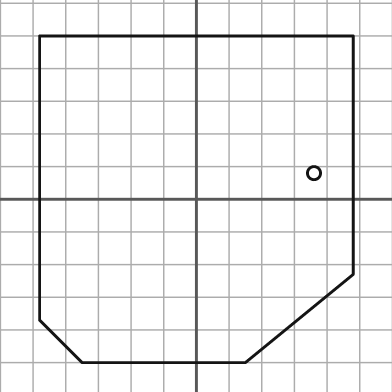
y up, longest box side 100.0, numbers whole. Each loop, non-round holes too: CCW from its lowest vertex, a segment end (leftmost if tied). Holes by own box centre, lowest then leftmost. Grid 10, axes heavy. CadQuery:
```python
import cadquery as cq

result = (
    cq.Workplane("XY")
    .moveTo(-35.0, -50.0)
    .lineTo(15.0, -50.0)
    .lineTo(48.0, -23.0)
    .lineTo(48.0, 50.0)
    .lineTo(-48.0, 50.0)
    .lineTo(-48.0, -37.0)
    .close()
    .moveTo(36.0, 8.0)
    .circle(2.0)
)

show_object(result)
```